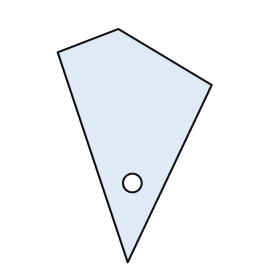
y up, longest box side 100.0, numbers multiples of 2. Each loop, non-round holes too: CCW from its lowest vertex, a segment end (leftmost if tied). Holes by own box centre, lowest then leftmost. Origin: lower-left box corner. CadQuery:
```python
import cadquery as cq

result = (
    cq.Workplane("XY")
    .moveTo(30.0, 0.0)
    .lineTo(66.0, 76.0)
    .lineTo(26.0, 100.0)
    .lineTo(0.0, 90.0)
    .close()
    .moveTo(32.0, 34.0)
    .circle(4.0)
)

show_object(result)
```